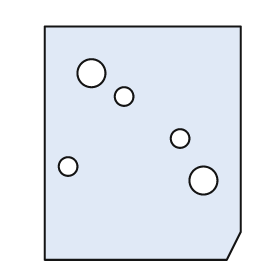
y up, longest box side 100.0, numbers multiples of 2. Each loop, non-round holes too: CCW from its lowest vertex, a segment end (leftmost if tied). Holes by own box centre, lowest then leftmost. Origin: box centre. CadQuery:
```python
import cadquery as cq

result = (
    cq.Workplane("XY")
    .moveTo(-42.0, -50.0)
    .lineTo(36.0, -50.0)
    .lineTo(42.0, -38.0)
    .lineTo(42.0, 50.0)
    .lineTo(-42.0, 50.0)
    .close()
    .moveTo(26.0, -16.0)
    .circle(6.0)
    .moveTo(-32.0, -10.0)
    .circle(4.0)
    .moveTo(16.0, 2.0)
    .circle(4.0)
    .moveTo(-8.0, 20.0)
    .circle(4.0)
    .moveTo(-22.0, 30.0)
    .circle(6.0)
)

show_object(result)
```